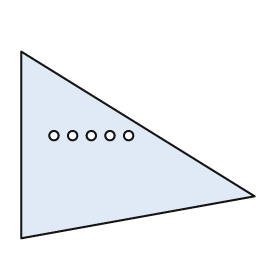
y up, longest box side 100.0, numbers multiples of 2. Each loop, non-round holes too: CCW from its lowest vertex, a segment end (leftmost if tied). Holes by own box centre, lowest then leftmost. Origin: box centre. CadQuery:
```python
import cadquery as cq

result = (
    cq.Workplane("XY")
    .moveTo(-50.0, -40.0)
    .lineTo(50.0, -22.0)
    .lineTo(-50.0, 40.0)
    .close()
    .moveTo(-36.0, 4.0)
    .circle(2.0)
    .moveTo(-28.0, 4.0)
    .circle(2.0)
    .moveTo(-20.0, 4.0)
    .circle(2.0)
    .moveTo(-12.0, 4.0)
    .circle(2.0)
    .moveTo(-4.0, 4.0)
    .circle(2.0)
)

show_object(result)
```